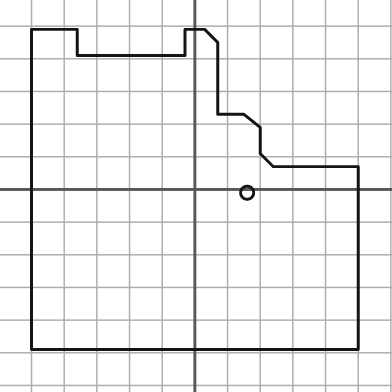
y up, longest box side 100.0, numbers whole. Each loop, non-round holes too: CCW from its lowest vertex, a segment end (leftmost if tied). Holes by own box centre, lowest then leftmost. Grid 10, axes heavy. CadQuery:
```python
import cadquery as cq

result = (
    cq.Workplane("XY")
    .moveTo(-50.0, -49.0)
    .lineTo(50.0, -49.0)
    .lineTo(50.0, 7.0)
    .lineTo(24.0, 7.0)
    .lineTo(20.0, 11.0)
    .lineTo(20.0, 19.0)
    .lineTo(15.0, 23.0)
    .lineTo(7.0, 23.0)
    .lineTo(7.0, 45.0)
    .lineTo(3.0, 49.0)
    .lineTo(-3.0, 49.0)
    .lineTo(-3.0, 41.0)
    .lineTo(-36.0, 41.0)
    .lineTo(-36.0, 49.0)
    .lineTo(-50.0, 49.0)
    .close()
    .moveTo(16.0, -1.0)
    .circle(2.0)
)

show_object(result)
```